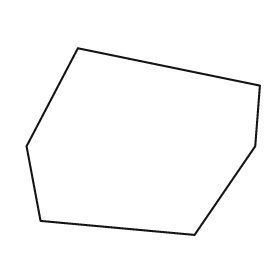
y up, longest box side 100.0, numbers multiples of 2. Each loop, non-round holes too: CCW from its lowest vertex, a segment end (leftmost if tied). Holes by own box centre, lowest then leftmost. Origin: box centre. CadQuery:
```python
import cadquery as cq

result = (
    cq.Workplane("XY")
    .moveTo(22.0, -40.0)
    .lineTo(48.0, -2.0)
    .lineTo(50.0, 24.0)
    .lineTo(-28.0, 40.0)
    .lineTo(-50.0, -2.0)
    .lineTo(-44.0, -34.0)
    .close()
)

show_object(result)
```